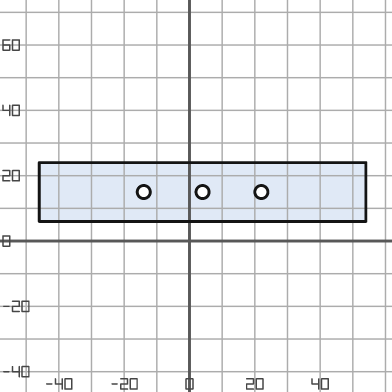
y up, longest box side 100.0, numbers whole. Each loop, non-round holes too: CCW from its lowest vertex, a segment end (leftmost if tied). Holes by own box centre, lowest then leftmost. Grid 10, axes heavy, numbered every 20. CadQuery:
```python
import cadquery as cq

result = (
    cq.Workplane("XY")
    .moveTo(-46.0, 6.0)
    .lineTo(54.0, 6.0)
    .lineTo(54.0, 24.0)
    .lineTo(-46.0, 24.0)
    .close()
    .moveTo(-14.0, 15.0)
    .circle(2.0)
    .moveTo(4.0, 15.0)
    .circle(2.0)
    .moveTo(22.0, 15.0)
    .circle(2.0)
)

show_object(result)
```